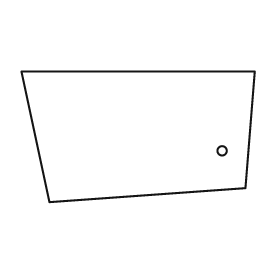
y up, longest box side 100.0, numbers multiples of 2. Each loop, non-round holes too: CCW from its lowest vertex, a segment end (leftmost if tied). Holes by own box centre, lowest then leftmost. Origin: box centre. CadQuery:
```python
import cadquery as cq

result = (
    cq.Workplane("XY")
    .moveTo(-38.0, -28.0)
    .lineTo(46.0, -22.0)
    .lineTo(50.0, 28.0)
    .lineTo(-50.0, 28.0)
    .close()
    .moveTo(36.0, -6.0)
    .circle(2.0)
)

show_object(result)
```